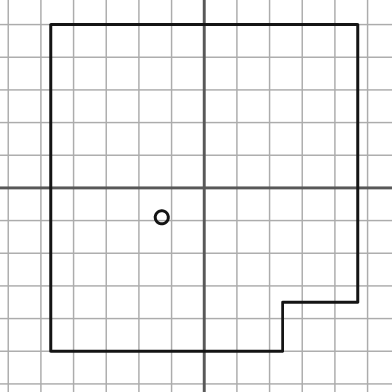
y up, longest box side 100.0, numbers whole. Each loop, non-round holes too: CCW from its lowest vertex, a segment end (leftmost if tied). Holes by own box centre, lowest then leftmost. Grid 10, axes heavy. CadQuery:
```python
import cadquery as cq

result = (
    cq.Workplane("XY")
    .moveTo(-47.0, -50.0)
    .lineTo(24.0, -50.0)
    .lineTo(24.0, -35.0)
    .lineTo(47.0, -35.0)
    .lineTo(47.0, 50.0)
    .lineTo(-47.0, 50.0)
    .close()
    .moveTo(-13.0, -9.0)
    .circle(2.0)
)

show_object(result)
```